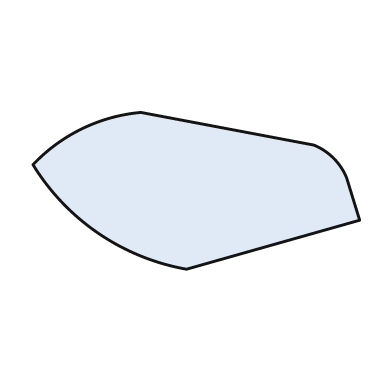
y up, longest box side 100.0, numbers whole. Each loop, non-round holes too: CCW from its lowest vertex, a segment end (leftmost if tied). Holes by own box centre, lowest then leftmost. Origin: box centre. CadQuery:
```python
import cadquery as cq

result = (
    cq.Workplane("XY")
    .moveTo(-3.0, -24.0)
    .lineTo(50.0, -9.0)
    .lineTo(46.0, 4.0)
    .threePointArc((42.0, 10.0), (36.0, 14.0))
    .lineTo(-17.0, 24.0)
    .threePointArc((-35.0, 19.0), (-50.0, 8.0))
    .threePointArc((-30.0, -13.0), (-3.0, -24.0))
    .close()
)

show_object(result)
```